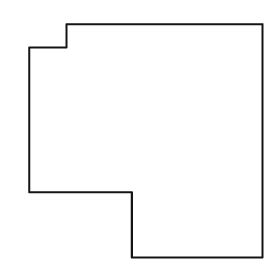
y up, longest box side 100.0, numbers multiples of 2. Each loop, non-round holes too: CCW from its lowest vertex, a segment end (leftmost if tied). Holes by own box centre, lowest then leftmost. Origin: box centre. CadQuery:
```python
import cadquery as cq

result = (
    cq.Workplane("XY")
    .moveTo(-6.0, -50.0)
    .lineTo(50.0, -50.0)
    .lineTo(50.0, 50.0)
    .lineTo(-34.0, 50.0)
    .lineTo(-34.0, 40.0)
    .lineTo(-50.0, 40.0)
    .lineTo(-50.0, -22.0)
    .lineTo(-6.0, -22.0)
    .close()
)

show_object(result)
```